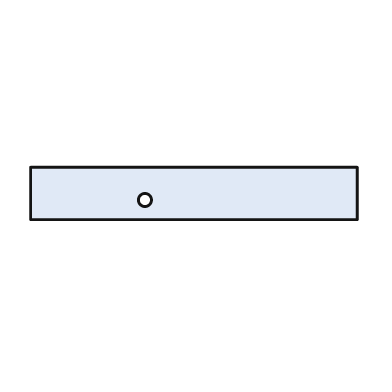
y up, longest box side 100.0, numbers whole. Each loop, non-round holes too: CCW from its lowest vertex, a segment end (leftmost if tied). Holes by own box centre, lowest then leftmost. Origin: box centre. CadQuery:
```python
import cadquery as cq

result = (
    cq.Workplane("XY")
    .moveTo(-50.0, -8.0)
    .lineTo(50.0, -8.0)
    .lineTo(50.0, 8.0)
    .lineTo(-50.0, 8.0)
    .close()
    .moveTo(-15.0, -2.0)
    .circle(2.0)
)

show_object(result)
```